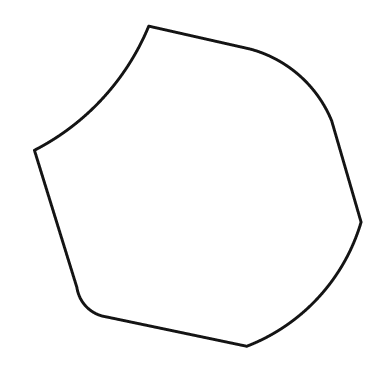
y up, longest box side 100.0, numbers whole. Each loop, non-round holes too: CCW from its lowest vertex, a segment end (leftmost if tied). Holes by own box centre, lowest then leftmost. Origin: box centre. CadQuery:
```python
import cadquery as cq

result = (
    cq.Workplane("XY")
    .moveTo(15.0, -49.0)
    .threePointArc((37.0, -34.0), (50.0, -11.0))
    .lineTo(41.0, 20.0)
    .threePointArc((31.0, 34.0), (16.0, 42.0))
    .lineTo(-15.0, 49.0)
    .threePointArc((-29.0, 27.0), (-50.0, 11.0))
    .lineTo(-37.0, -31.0)
    .threePointArc((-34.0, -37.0), (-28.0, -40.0))
    .close()
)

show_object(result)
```